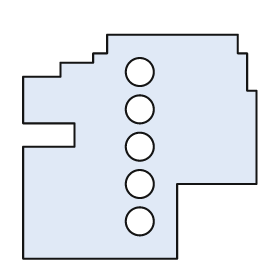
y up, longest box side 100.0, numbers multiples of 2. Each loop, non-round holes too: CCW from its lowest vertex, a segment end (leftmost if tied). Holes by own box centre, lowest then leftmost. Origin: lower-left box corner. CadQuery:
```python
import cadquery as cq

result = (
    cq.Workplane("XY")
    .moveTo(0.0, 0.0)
    .lineTo(66.0, 0.0)
    .lineTo(66.0, 32.0)
    .lineTo(100.0, 32.0)
    .lineTo(100.0, 72.0)
    .lineTo(96.0, 72.0)
    .lineTo(96.0, 88.0)
    .lineTo(92.0, 88.0)
    .lineTo(92.0, 96.0)
    .lineTo(36.0, 96.0)
    .lineTo(36.0, 88.0)
    .lineTo(30.0, 88.0)
    .lineTo(30.0, 84.0)
    .lineTo(16.0, 84.0)
    .lineTo(16.0, 78.0)
    .lineTo(0.0, 78.0)
    .lineTo(0.0, 58.0)
    .lineTo(22.0, 58.0)
    .lineTo(22.0, 48.0)
    .lineTo(0.0, 48.0)
    .close()
    .moveTo(50.0, 16.0)
    .circle(6.0)
    .moveTo(50.0, 32.0)
    .circle(6.0)
    .moveTo(50.0, 48.0)
    .circle(6.0)
    .moveTo(50.0, 64.0)
    .circle(6.0)
    .moveTo(50.0, 80.0)
    .circle(6.0)
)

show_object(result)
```